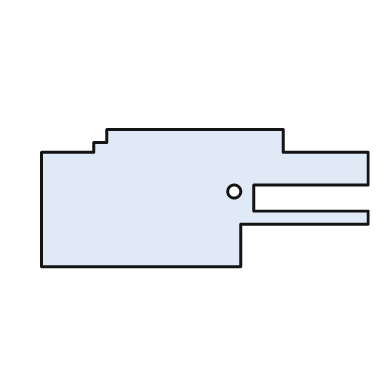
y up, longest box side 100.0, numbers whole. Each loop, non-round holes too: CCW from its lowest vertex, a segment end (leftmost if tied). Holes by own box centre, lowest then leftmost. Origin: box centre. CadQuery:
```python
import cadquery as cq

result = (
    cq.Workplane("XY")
    .moveTo(-50.0, -21.0)
    .lineTo(11.0, -21.0)
    .lineTo(11.0, -8.0)
    .lineTo(50.0, -8.0)
    .lineTo(50.0, -4.0)
    .lineTo(15.0, -4.0)
    .lineTo(15.0, 4.0)
    .lineTo(50.0, 4.0)
    .lineTo(50.0, 14.0)
    .lineTo(24.0, 14.0)
    .lineTo(24.0, 21.0)
    .lineTo(-30.0, 21.0)
    .lineTo(-30.0, 17.0)
    .lineTo(-34.0, 17.0)
    .lineTo(-34.0, 14.0)
    .lineTo(-50.0, 14.0)
    .close()
    .moveTo(9.0, 2.0)
    .circle(2.0)
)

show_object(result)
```